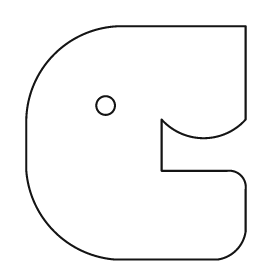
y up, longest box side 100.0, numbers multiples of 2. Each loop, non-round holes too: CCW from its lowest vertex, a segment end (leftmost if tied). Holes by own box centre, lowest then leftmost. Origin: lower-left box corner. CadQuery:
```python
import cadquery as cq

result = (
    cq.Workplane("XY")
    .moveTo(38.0, 0.0)
    .lineTo(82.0, 0.0)
    .threePointArc((90.0, 4.0), (94.0, 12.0))
    .lineTo(94.0, 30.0)
    .threePointArc((92.0, 36.0), (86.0, 38.0))
    .lineTo(58.0, 38.0)
    .lineTo(58.0, 60.0)
    .threePointArc((76.0, 52.0), (94.0, 60.0))
    .lineTo(94.0, 100.0)
    .lineTo(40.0, 100.0)
    .threePointArc((12.0, 88.0), (0.0, 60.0))
    .lineTo(0.0, 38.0)
    .threePointArc((12.0, 12.0), (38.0, 0.0))
    .close()
    .moveTo(34.0, 66.0)
    .circle(4.0)
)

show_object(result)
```